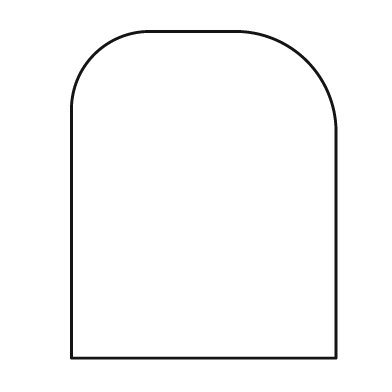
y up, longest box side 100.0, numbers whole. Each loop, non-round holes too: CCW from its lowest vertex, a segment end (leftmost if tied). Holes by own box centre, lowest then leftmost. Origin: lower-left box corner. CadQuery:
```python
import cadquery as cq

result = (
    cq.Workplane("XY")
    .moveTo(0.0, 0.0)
    .lineTo(81.0, 0.0)
    .lineTo(81.0, 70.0)
    .threePointArc((72.0, 91.0), (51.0, 100.0))
    .lineTo(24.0, 100.0)
    .threePointArc((7.0, 93.0), (0.0, 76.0))
    .close()
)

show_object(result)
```